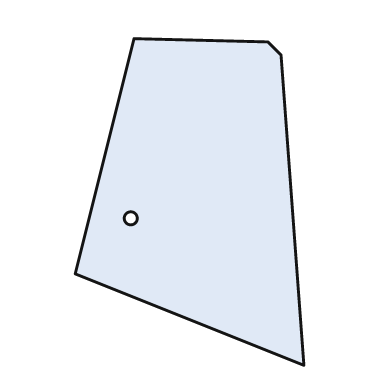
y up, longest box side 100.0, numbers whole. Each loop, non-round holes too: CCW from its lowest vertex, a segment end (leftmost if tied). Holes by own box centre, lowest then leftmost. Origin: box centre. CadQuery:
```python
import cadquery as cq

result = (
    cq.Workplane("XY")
    .moveTo(35.0, -50.0)
    .lineTo(28.0, 45.0)
    .lineTo(24.0, 49.0)
    .lineTo(-17.0, 50.0)
    .lineTo(-35.0, -22.0)
    .close()
    .moveTo(-18.0, -5.0)
    .circle(2.0)
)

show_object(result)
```